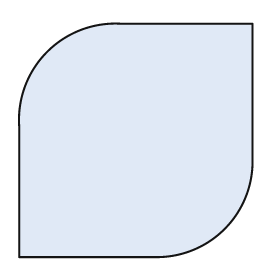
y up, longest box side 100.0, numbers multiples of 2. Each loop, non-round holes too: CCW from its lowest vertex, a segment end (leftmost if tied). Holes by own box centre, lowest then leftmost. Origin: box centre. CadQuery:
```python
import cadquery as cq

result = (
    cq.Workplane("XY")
    .moveTo(-50.0, -50.0)
    .lineTo(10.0, -50.0)
    .threePointArc((38.0, -38.0), (50.0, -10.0))
    .lineTo(50.0, 50.0)
    .lineTo(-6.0, 50.0)
    .threePointArc((-38.0, 38.0), (-50.0, 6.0))
    .close()
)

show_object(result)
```